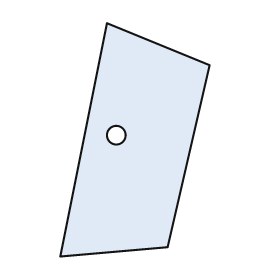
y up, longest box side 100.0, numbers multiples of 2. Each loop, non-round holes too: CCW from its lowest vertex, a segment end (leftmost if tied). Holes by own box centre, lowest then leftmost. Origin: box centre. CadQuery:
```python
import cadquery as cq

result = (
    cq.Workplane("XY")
    .moveTo(-32.0, -50.0)
    .lineTo(14.0, -46.0)
    .lineTo(32.0, 32.0)
    .lineTo(-12.0, 50.0)
    .close()
    .moveTo(-8.0, 2.0)
    .circle(4.0)
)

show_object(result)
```